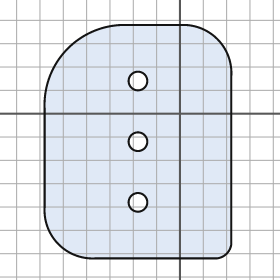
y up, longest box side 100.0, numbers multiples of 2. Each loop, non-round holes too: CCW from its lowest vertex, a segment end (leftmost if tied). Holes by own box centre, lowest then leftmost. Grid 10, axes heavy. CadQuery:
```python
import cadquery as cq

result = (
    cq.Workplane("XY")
    .moveTo(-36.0, -62.0)
    .lineTo(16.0, -62.0)
    .threePointArc((20.0, -60.0), (22.0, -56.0))
    .lineTo(22.0, 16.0)
    .threePointArc((16.0, 32.0), (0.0, 38.0))
    .lineTo(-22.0, 38.0)
    .threePointArc((-48.0, 28.0), (-58.0, 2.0))
    .lineTo(-58.0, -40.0)
    .threePointArc((-52.0, -56.0), (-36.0, -62.0))
    .close()
    .moveTo(-18.0, -38.0)
    .circle(4.0)
    .moveTo(-18.0, -12.0)
    .circle(4.0)
    .moveTo(-18.0, 14.0)
    .circle(4.0)
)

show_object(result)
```